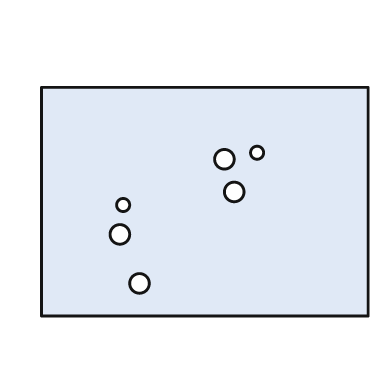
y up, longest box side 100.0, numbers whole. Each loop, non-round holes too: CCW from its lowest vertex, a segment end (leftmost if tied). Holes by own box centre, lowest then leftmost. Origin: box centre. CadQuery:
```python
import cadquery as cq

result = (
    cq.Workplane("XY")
    .moveTo(-50.0, -35.0)
    .lineTo(50.0, -35.0)
    .lineTo(50.0, 35.0)
    .lineTo(-50.0, 35.0)
    .close()
    .moveTo(-20.0, -25.0)
    .circle(3.0)
    .moveTo(-26.0, -10.0)
    .circle(3.0)
    .moveTo(-25.0, -1.0)
    .circle(2.0)
    .moveTo(9.0, 3.0)
    .circle(3.0)
    .moveTo(6.0, 13.0)
    .circle(3.0)
    .moveTo(16.0, 15.0)
    .circle(2.0)
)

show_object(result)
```